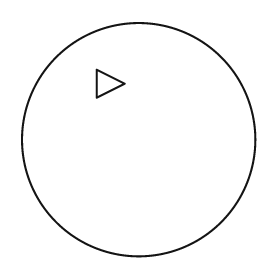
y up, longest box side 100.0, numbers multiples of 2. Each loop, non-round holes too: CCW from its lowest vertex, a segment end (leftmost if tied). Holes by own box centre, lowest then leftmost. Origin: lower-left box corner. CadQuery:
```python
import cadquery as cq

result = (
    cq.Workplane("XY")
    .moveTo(50.0, 50.0)
    .circle(50.0)
    .moveTo(32.0, 68.0)
    .lineTo(44.0, 74.0)
    .lineTo(32.0, 80.0)
    .close()
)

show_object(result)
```